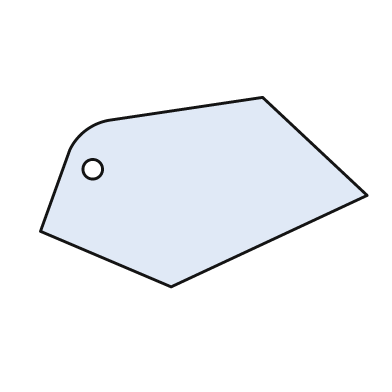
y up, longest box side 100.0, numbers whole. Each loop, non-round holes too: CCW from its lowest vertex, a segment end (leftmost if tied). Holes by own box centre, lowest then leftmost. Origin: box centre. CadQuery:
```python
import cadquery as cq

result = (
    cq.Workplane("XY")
    .moveTo(-10.0, -29.0)
    .lineTo(50.0, -1.0)
    .lineTo(18.0, 29.0)
    .lineTo(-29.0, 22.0)
    .threePointArc((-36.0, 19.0), (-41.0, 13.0))
    .lineTo(-50.0, -12.0)
    .close()
    .moveTo(-34.0, 7.0)
    .circle(3.0)
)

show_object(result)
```